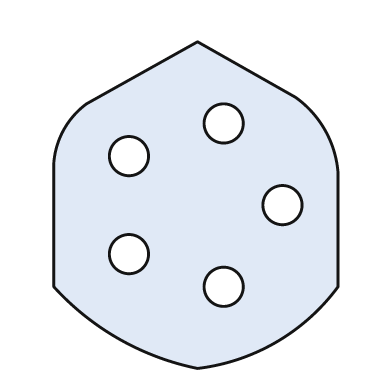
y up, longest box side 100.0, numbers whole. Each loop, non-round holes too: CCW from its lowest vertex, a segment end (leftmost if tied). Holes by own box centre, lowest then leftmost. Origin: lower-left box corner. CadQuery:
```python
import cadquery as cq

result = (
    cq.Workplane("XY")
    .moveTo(44.0, 0.0)
    .threePointArc((68.0, 8.0), (87.0, 25.0))
    .lineTo(87.0, 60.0)
    .threePointArc((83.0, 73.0), (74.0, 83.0))
    .lineTo(44.0, 100.0)
    .lineTo(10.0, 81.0)
    .threePointArc((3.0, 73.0), (0.0, 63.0))
    .lineTo(0.0, 25.0)
    .threePointArc((20.0, 9.0), (44.0, 0.0))
    .close()
    .moveTo(52.0, 25.0)
    .circle(6.0)
    .moveTo(23.0, 35.0)
    .circle(6.0)
    .moveTo(70.0, 50.0)
    .circle(6.0)
    .moveTo(23.0, 65.0)
    .circle(6.0)
    .moveTo(52.0, 75.0)
    .circle(6.0)
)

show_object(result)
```